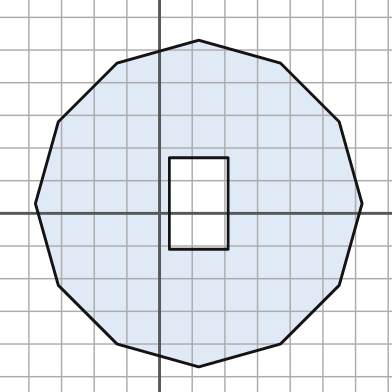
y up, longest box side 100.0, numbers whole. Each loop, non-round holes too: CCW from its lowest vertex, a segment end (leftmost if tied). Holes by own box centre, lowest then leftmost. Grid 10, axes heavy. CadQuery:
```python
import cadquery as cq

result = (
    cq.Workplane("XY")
    .moveTo(12.0, -47.0)
    .lineTo(37.0, -40.0)
    .lineTo(55.0, -22.0)
    .lineTo(62.0, 3.0)
    .lineTo(55.0, 28.0)
    .lineTo(37.0, 46.0)
    .lineTo(12.0, 53.0)
    .lineTo(-13.0, 46.0)
    .lineTo(-31.0, 28.0)
    .lineTo(-38.0, 3.0)
    .lineTo(-31.0, -22.0)
    .lineTo(-13.0, -40.0)
    .close()
    .moveTo(3.0, -11.0)
    .lineTo(21.0, -11.0)
    .lineTo(21.0, 17.0)
    .lineTo(3.0, 17.0)
    .close()
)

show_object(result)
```